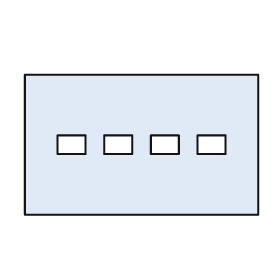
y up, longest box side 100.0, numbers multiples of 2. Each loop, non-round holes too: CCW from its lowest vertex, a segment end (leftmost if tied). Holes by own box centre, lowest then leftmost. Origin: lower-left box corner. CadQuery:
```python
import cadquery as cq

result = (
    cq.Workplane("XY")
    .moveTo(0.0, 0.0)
    .lineTo(100.0, 0.0)
    .lineTo(100.0, 60.0)
    .lineTo(0.0, 60.0)
    .close()
    .moveTo(14.0, 26.0)
    .lineTo(26.0, 26.0)
    .lineTo(26.0, 34.0)
    .lineTo(14.0, 34.0)
    .close()
    .moveTo(34.0, 26.0)
    .lineTo(46.0, 26.0)
    .lineTo(46.0, 34.0)
    .lineTo(34.0, 34.0)
    .close()
    .moveTo(54.0, 26.0)
    .lineTo(66.0, 26.0)
    .lineTo(66.0, 34.0)
    .lineTo(54.0, 34.0)
    .close()
    .moveTo(74.0, 26.0)
    .lineTo(86.0, 26.0)
    .lineTo(86.0, 34.0)
    .lineTo(74.0, 34.0)
    .close()
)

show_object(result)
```